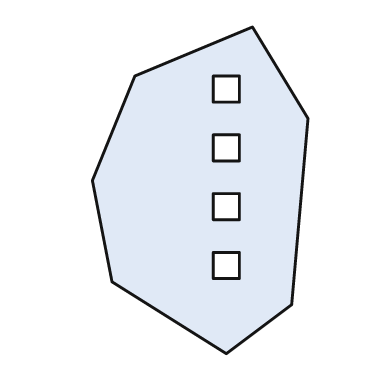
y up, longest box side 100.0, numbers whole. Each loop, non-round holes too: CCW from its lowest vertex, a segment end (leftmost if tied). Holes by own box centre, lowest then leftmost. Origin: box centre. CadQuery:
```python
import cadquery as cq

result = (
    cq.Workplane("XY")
    .moveTo(8.0, -50.0)
    .lineTo(28.0, -35.0)
    .lineTo(33.0, 22.0)
    .lineTo(16.0, 50.0)
    .lineTo(-20.0, 35.0)
    .lineTo(-33.0, 3.0)
    .lineTo(-27.0, -28.0)
    .close()
    .moveTo(4.0, -27.0)
    .lineTo(12.0, -27.0)
    .lineTo(12.0, -19.0)
    .lineTo(4.0, -19.0)
    .close()
    .moveTo(4.0, -9.0)
    .lineTo(12.0, -9.0)
    .lineTo(12.0, -1.0)
    .lineTo(4.0, -1.0)
    .close()
    .moveTo(4.0, 9.0)
    .lineTo(12.0, 9.0)
    .lineTo(12.0, 17.0)
    .lineTo(4.0, 17.0)
    .close()
    .moveTo(4.0, 27.0)
    .lineTo(12.0, 27.0)
    .lineTo(12.0, 35.0)
    .lineTo(4.0, 35.0)
    .close()
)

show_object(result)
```